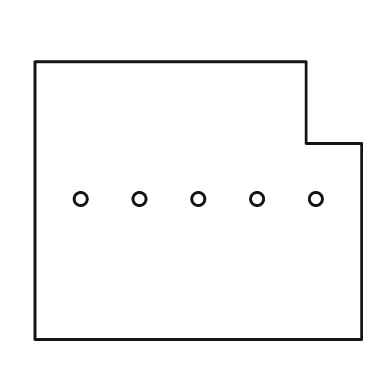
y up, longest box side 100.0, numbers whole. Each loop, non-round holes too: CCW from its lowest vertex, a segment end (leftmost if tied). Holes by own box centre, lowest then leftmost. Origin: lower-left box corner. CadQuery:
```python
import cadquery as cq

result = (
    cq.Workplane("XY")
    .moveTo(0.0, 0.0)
    .lineTo(100.0, 0.0)
    .lineTo(100.0, 60.0)
    .lineTo(83.0, 60.0)
    .lineTo(83.0, 85.0)
    .lineTo(0.0, 85.0)
    .close()
    .moveTo(14.0, 43.0)
    .circle(2.0)
    .moveTo(32.0, 43.0)
    .circle(2.0)
    .moveTo(50.0, 43.0)
    .circle(2.0)
    .moveTo(68.0, 43.0)
    .circle(2.0)
    .moveTo(86.0, 43.0)
    .circle(2.0)
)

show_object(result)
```